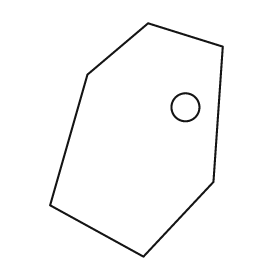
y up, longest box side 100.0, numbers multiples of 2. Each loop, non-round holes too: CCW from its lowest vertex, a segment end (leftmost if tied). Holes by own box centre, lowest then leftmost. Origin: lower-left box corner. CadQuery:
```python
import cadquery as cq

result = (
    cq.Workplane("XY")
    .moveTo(40.0, 0.0)
    .lineTo(70.0, 32.0)
    .lineTo(74.0, 90.0)
    .lineTo(42.0, 100.0)
    .lineTo(16.0, 78.0)
    .lineTo(0.0, 22.0)
    .close()
    .moveTo(58.0, 64.0)
    .circle(6.0)
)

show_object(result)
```